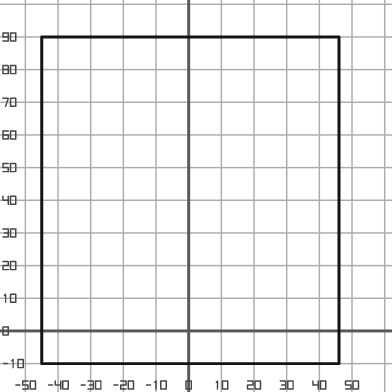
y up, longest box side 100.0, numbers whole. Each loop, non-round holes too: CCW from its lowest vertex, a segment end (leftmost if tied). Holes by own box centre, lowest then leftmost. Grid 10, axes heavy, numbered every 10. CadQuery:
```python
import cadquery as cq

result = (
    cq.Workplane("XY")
    .moveTo(-45.0, -10.0)
    .lineTo(46.0, -10.0)
    .lineTo(46.0, 90.0)
    .lineTo(-45.0, 90.0)
    .close()
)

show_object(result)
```